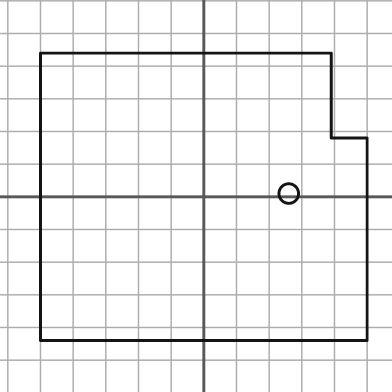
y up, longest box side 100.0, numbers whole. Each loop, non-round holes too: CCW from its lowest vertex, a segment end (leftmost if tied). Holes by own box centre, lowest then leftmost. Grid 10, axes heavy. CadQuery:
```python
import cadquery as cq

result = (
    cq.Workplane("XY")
    .moveTo(-50.0, -44.0)
    .lineTo(50.0, -44.0)
    .lineTo(50.0, 18.0)
    .lineTo(39.0, 18.0)
    .lineTo(39.0, 44.0)
    .lineTo(-50.0, 44.0)
    .close()
    .moveTo(26.0, 1.0)
    .circle(3.0)
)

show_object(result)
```